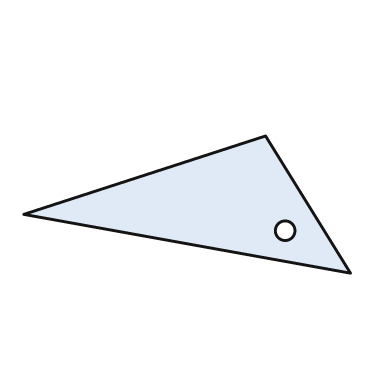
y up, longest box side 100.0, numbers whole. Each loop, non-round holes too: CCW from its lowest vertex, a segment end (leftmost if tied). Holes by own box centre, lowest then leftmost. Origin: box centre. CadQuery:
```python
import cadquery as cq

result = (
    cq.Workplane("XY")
    .moveTo(50.0, -21.0)
    .lineTo(24.0, 21.0)
    .lineTo(-50.0, -3.0)
    .close()
    .moveTo(30.0, -8.0)
    .circle(3.0)
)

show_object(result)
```